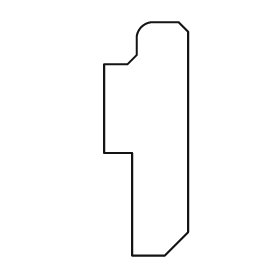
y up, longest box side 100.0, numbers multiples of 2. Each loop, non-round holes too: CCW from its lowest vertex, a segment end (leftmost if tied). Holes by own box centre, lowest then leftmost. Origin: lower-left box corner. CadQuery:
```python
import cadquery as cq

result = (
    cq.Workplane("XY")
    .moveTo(12.0, 0.0)
    .lineTo(26.0, 0.0)
    .lineTo(36.0, 10.0)
    .lineTo(36.0, 96.0)
    .lineTo(32.0, 100.0)
    .lineTo(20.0, 100.0)
    .threePointArc((16.0, 98.0), (14.0, 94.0))
    .lineTo(14.0, 86.0)
    .lineTo(10.0, 82.0)
    .lineTo(0.0, 82.0)
    .lineTo(0.0, 44.0)
    .lineTo(12.0, 44.0)
    .close()
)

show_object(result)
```